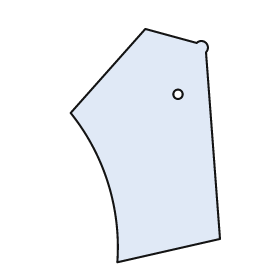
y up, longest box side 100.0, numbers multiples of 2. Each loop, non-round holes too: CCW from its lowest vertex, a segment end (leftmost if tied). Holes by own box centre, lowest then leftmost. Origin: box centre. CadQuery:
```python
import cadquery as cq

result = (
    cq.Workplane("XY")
    .moveTo(-12.0, -50.0)
    .lineTo(32.0, -40.0)
    .lineTo(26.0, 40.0)
    .threePointArc((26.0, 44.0), (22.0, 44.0))
    .lineTo(0.0, 50.0)
    .lineTo(-32.0, 14.0)
    .threePointArc((-16.0, -16.0), (-12.0, -50.0))
    .close()
    .moveTo(14.0, 22.0)
    .circle(2.0)
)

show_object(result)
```